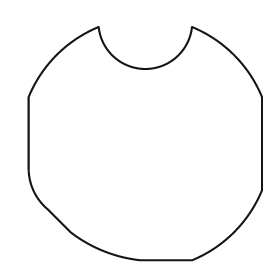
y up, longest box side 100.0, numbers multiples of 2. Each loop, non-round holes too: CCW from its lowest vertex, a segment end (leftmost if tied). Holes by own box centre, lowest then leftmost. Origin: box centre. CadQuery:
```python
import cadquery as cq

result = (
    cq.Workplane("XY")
    .moveTo(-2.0, -50.0)
    .lineTo(20.0, -50.0)
    .threePointArc((38.0, -38.0), (50.0, -20.0))
    .lineTo(50.0, 20.0)
    .threePointArc((38.0, 38.0), (20.0, 50.0))
    .threePointArc((0.0, 32.0), (-20.0, 50.0))
    .threePointArc((-38.0, 38.0), (-50.0, 20.0))
    .lineTo(-50.0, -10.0)
    .threePointArc((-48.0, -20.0), (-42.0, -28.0))
    .lineTo(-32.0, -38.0)
    .threePointArc((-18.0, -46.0), (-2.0, -50.0))
    .close()
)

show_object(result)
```